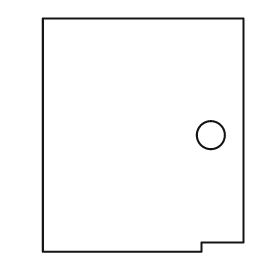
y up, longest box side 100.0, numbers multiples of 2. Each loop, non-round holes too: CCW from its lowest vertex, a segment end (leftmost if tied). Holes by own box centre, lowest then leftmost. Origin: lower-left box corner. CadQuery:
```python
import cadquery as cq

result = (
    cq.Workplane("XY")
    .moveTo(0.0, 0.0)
    .lineTo(68.0, 0.0)
    .lineTo(68.0, 4.0)
    .lineTo(86.0, 4.0)
    .lineTo(86.0, 100.0)
    .lineTo(0.0, 100.0)
    .close()
    .moveTo(72.0, 50.0)
    .circle(6.0)
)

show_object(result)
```